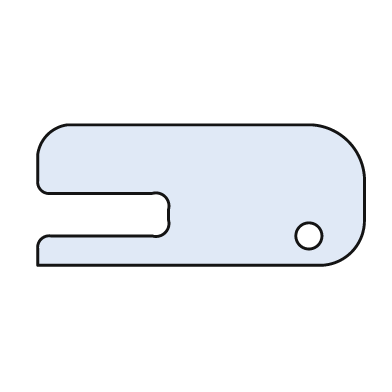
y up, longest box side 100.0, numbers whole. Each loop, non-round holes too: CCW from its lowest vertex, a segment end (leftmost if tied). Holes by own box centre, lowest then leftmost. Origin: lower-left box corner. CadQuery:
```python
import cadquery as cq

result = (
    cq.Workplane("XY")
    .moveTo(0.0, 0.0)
    .lineTo(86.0, 0.0)
    .threePointArc((96.0, 4.0), (100.0, 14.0))
    .lineTo(100.0, 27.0)
    .threePointArc((95.0, 38.0), (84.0, 43.0))
    .lineTo(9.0, 43.0)
    .threePointArc((3.0, 40.0), (0.0, 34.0))
    .lineTo(0.0, 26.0)
    .threePointArc((1.0, 23.0), (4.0, 22.0))
    .lineTo(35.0, 22.0)
    .threePointArc((39.0, 21.0), (40.0, 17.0))
    .lineTo(40.0, 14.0)
    .threePointArc((39.0, 10.0), (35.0, 9.0))
    .lineTo(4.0, 9.0)
    .threePointArc((1.0, 8.0), (0.0, 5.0))
    .close()
    .moveTo(83.0, 9.0)
    .circle(4.0)
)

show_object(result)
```